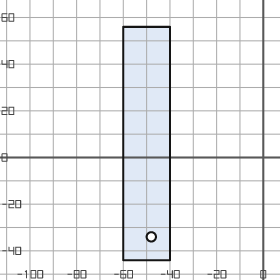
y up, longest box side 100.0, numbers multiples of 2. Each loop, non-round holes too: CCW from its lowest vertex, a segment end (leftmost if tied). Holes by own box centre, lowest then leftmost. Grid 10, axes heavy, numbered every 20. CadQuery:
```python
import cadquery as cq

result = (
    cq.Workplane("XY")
    .moveTo(-60.0, -44.0)
    .lineTo(-40.0, -44.0)
    .lineTo(-40.0, 56.0)
    .lineTo(-60.0, 56.0)
    .close()
    .moveTo(-48.0, -34.0)
    .circle(2.0)
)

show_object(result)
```